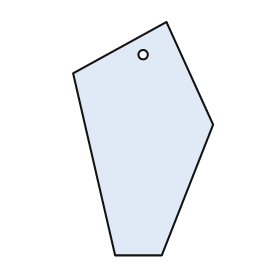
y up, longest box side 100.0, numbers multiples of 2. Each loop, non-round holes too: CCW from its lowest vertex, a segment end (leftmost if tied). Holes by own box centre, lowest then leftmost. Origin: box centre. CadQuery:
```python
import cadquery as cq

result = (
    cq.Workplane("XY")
    .moveTo(-12.0, -50.0)
    .lineTo(8.0, -50.0)
    .lineTo(30.0, 6.0)
    .lineTo(10.0, 50.0)
    .lineTo(-30.0, 28.0)
    .close()
    .moveTo(0.0, 36.0)
    .circle(2.0)
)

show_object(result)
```